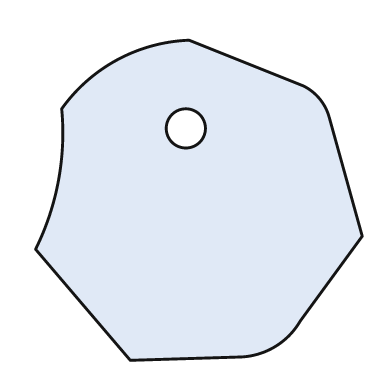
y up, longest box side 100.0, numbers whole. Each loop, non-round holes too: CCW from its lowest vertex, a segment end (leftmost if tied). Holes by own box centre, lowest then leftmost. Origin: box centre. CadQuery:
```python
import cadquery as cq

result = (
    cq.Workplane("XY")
    .moveTo(-21.0, -49.0)
    .lineTo(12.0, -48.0)
    .threePointArc((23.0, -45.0), (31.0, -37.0))
    .lineTo(50.0, -11.0)
    .lineTo(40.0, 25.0)
    .threePointArc((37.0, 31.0), (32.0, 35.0))
    .lineTo(-3.0, 49.0)
    .threePointArc((-25.0, 43.0), (-42.0, 28.0))
    .threePointArc((-43.0, 6.0), (-50.0, -15.0))
    .close()
    .moveTo(-4.0, 22.0)
    .circle(6.0)
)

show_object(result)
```